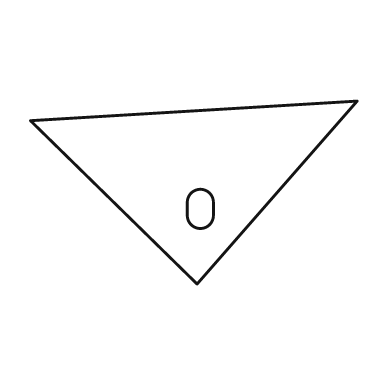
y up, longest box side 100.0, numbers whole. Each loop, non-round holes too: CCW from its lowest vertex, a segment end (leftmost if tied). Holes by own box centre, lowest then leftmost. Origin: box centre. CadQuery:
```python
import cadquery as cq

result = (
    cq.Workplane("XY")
    .moveTo(1.0, -28.0)
    .lineTo(50.0, 28.0)
    .lineTo(-50.0, 22.0)
    .close()
    .moveTo(-2.0, -7.0)
    .threePointArc((2.0, -11.0), (6.0, -7.0))
    .lineTo(6.0, -3.0)
    .threePointArc((2.0, 1.0), (-2.0, -3.0))
    .close()
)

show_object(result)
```